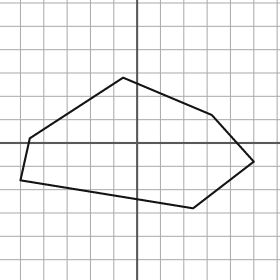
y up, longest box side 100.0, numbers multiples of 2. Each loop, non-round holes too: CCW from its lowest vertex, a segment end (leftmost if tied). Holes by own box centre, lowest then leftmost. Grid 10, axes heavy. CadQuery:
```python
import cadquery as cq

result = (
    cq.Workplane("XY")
    .moveTo(24.0, -28.0)
    .lineTo(50.0, -8.0)
    .lineTo(32.0, 12.0)
    .lineTo(-6.0, 28.0)
    .lineTo(-46.0, 2.0)
    .lineTo(-50.0, -16.0)
    .close()
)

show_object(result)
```